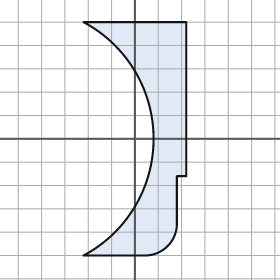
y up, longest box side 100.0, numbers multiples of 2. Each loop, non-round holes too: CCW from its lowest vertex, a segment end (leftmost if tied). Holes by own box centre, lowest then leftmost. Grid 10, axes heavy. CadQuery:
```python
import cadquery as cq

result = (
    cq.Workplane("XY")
    .moveTo(-22.0, -50.0)
    .lineTo(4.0, -50.0)
    .threePointArc((14.0, -46.0), (18.0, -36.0))
    .lineTo(18.0, -16.0)
    .lineTo(22.0, -16.0)
    .lineTo(22.0, 50.0)
    .lineTo(-22.0, 50.0)
    .threePointArc((8.0, 0.0), (-22.0, -50.0))
    .close()
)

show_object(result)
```